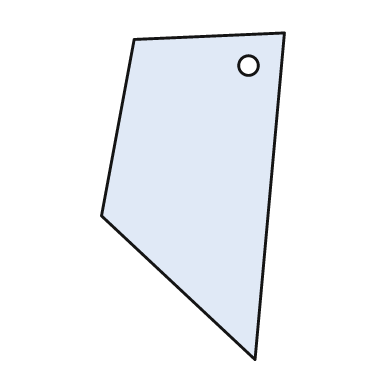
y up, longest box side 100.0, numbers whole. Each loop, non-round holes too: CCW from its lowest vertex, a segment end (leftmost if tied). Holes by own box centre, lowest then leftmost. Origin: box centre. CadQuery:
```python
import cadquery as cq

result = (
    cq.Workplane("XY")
    .moveTo(19.0, -50.0)
    .lineTo(28.0, 50.0)
    .lineTo(-18.0, 48.0)
    .lineTo(-28.0, -6.0)
    .close()
    .moveTo(17.0, 40.0)
    .circle(3.0)
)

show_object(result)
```